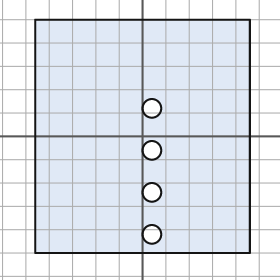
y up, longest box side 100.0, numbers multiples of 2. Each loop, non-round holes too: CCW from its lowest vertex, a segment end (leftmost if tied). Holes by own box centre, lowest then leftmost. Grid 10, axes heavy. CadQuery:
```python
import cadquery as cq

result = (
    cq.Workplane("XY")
    .moveTo(-46.0, -50.0)
    .lineTo(46.0, -50.0)
    .lineTo(46.0, 50.0)
    .lineTo(-46.0, 50.0)
    .close()
    .moveTo(4.0, -42.0)
    .circle(4.0)
    .moveTo(4.0, -24.0)
    .circle(4.0)
    .moveTo(4.0, -6.0)
    .circle(4.0)
    .moveTo(4.0, 12.0)
    .circle(4.0)
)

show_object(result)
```